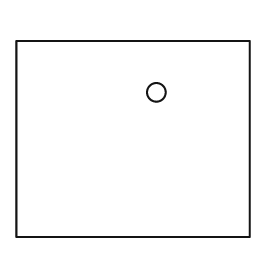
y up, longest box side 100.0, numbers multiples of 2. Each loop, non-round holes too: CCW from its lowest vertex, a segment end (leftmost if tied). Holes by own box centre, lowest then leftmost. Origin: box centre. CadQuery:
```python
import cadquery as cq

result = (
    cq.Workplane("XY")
    .moveTo(-50.0, -42.0)
    .lineTo(50.0, -42.0)
    .lineTo(50.0, 42.0)
    .lineTo(-50.0, 42.0)
    .close()
    .moveTo(10.0, 20.0)
    .circle(4.0)
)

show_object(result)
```